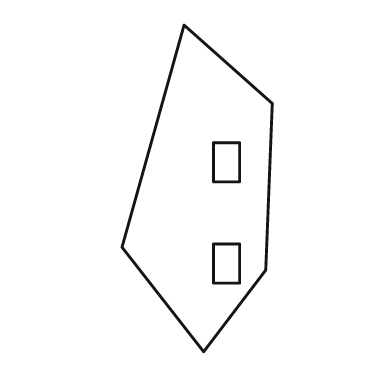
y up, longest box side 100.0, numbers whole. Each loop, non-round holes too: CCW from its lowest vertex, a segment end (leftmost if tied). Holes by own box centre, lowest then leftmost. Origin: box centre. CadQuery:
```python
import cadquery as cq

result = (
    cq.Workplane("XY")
    .moveTo(2.0, -50.0)
    .lineTo(21.0, -25.0)
    .lineTo(23.0, 26.0)
    .lineTo(-4.0, 50.0)
    .lineTo(-23.0, -18.0)
    .close()
    .moveTo(5.0, -29.0)
    .lineTo(13.0, -29.0)
    .lineTo(13.0, -17.0)
    .lineTo(5.0, -17.0)
    .close()
    .moveTo(5.0, 2.0)
    .lineTo(13.0, 2.0)
    .lineTo(13.0, 14.0)
    .lineTo(5.0, 14.0)
    .close()
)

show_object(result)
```